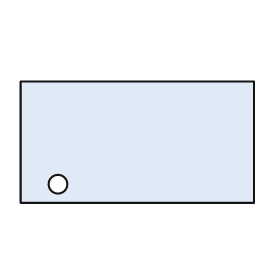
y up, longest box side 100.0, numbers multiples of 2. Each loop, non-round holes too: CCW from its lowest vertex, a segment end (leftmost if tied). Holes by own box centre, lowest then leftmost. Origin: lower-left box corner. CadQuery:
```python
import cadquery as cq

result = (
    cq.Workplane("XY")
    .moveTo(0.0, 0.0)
    .lineTo(100.0, 0.0)
    .lineTo(100.0, 52.0)
    .lineTo(0.0, 52.0)
    .close()
    .moveTo(16.0, 8.0)
    .circle(4.0)
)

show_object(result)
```